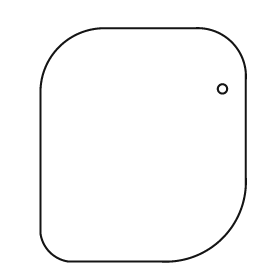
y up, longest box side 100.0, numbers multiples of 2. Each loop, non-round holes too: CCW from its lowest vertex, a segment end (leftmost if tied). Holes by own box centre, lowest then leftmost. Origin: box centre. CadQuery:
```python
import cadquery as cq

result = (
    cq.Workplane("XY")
    .moveTo(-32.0, -50.0)
    .lineTo(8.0, -50.0)
    .threePointArc((34.0, -40.0), (44.0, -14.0))
    .lineTo(44.0, 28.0)
    .threePointArc((38.0, 44.0), (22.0, 50.0))
    .lineTo(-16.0, 50.0)
    .threePointArc((-36.0, 42.0), (-44.0, 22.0))
    .lineTo(-44.0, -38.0)
    .threePointArc((-40.0, -46.0), (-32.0, -50.0))
    .close()
    .moveTo(34.0, 24.0)
    .circle(2.0)
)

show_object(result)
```